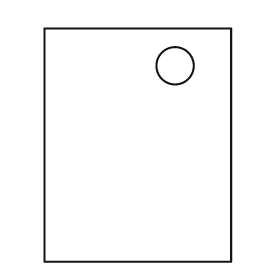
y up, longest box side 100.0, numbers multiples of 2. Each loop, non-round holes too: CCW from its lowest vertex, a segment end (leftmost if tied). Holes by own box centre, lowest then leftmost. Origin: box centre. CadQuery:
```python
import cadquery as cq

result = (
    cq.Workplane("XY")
    .moveTo(-40.0, -50.0)
    .lineTo(40.0, -50.0)
    .lineTo(40.0, 50.0)
    .lineTo(-40.0, 50.0)
    .close()
    .moveTo(16.0, 34.0)
    .circle(8.0)
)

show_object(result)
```